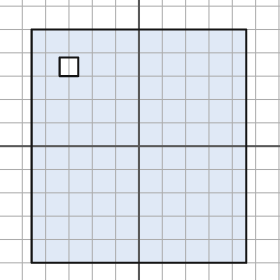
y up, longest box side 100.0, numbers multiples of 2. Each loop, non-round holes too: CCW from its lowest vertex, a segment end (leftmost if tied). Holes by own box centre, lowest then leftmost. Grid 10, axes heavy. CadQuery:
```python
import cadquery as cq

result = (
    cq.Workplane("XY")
    .moveTo(-46.0, -50.0)
    .lineTo(46.0, -50.0)
    .lineTo(46.0, 50.0)
    .lineTo(-46.0, 50.0)
    .close()
    .moveTo(-34.0, 30.0)
    .lineTo(-26.0, 30.0)
    .lineTo(-26.0, 38.0)
    .lineTo(-34.0, 38.0)
    .close()
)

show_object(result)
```